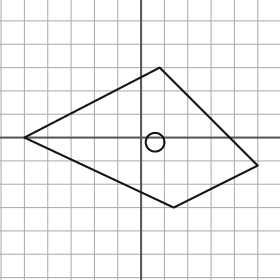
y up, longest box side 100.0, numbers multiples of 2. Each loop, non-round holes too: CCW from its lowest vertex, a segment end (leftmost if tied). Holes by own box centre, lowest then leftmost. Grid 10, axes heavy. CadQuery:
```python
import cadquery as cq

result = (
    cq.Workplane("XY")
    .moveTo(14.0, -30.0)
    .lineTo(50.0, -12.0)
    .lineTo(8.0, 30.0)
    .lineTo(-50.0, 0.0)
    .close()
    .moveTo(6.0, -2.0)
    .circle(4.0)
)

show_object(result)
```